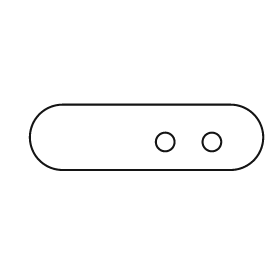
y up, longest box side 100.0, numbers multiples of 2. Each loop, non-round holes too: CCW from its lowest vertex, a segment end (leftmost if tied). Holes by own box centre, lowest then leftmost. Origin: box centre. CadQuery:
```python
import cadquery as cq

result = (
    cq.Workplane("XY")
    .moveTo(-36.0, -14.0)
    .lineTo(36.0, -14.0)
    .threePointArc((50.0, 0.0), (36.0, 14.0))
    .lineTo(-36.0, 14.0)
    .threePointArc((-50.0, 0.0), (-36.0, -14.0))
    .close()
    .moveTo(8.0, -2.0)
    .circle(4.0)
    .moveTo(28.0, -2.0)
    .circle(4.0)
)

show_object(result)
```